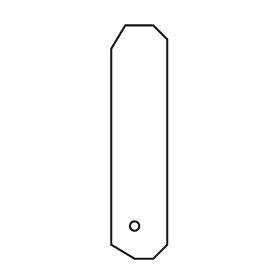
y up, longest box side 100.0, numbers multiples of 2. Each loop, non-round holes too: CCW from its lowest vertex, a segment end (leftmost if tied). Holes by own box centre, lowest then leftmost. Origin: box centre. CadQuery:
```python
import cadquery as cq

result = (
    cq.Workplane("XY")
    .moveTo(-2.0, -50.0)
    .lineTo(6.0, -50.0)
    .lineTo(12.0, -44.0)
    .lineTo(12.0, 44.0)
    .lineTo(6.0, 50.0)
    .lineTo(-6.0, 50.0)
    .lineTo(-12.0, 40.0)
    .lineTo(-12.0, -44.0)
    .close()
    .moveTo(-2.0, -36.0)
    .circle(2.0)
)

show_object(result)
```